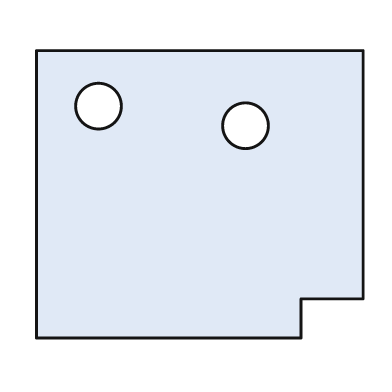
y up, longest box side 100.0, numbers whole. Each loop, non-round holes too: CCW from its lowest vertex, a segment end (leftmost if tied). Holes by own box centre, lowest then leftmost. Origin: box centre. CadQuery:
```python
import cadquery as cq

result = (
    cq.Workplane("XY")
    .moveTo(-50.0, -44.0)
    .lineTo(31.0, -44.0)
    .lineTo(31.0, -32.0)
    .lineTo(50.0, -32.0)
    .lineTo(50.0, 44.0)
    .lineTo(-50.0, 44.0)
    .close()
    .moveTo(14.0, 21.0)
    .circle(7.0)
    .moveTo(-31.0, 27.0)
    .circle(7.0)
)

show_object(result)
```